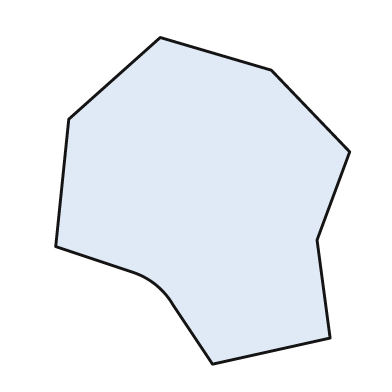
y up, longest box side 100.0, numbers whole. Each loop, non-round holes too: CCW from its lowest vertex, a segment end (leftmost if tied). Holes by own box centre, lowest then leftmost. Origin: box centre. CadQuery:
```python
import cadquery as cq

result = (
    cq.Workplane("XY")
    .moveTo(3.0, -50.0)
    .lineTo(39.0, -42.0)
    .lineTo(35.0, -12.0)
    .lineTo(45.0, 15.0)
    .lineTo(21.0, 40.0)
    .lineTo(-13.0, 50.0)
    .lineTo(-41.0, 25.0)
    .lineTo(-45.0, -14.0)
    .lineTo(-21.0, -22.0)
    .threePointArc((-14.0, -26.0), (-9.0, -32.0))
    .close()
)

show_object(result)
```